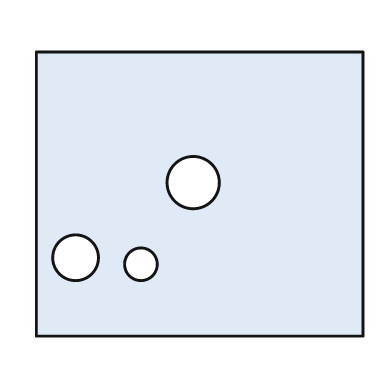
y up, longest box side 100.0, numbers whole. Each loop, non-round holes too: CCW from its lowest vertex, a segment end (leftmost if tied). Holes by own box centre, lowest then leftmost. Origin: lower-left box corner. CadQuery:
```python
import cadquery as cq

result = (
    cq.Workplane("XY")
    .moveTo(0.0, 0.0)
    .lineTo(100.0, 0.0)
    .lineTo(100.0, 87.0)
    .lineTo(0.0, 87.0)
    .close()
    .moveTo(32.0, 22.0)
    .circle(5.0)
    .moveTo(12.0, 24.0)
    .circle(7.0)
    .moveTo(48.0, 47.0)
    .circle(8.0)
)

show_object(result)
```